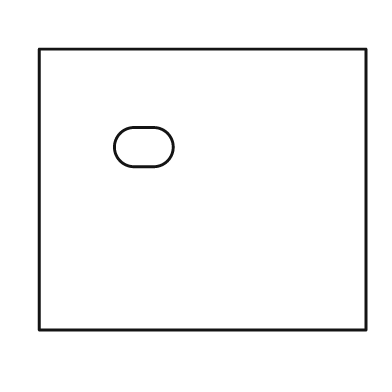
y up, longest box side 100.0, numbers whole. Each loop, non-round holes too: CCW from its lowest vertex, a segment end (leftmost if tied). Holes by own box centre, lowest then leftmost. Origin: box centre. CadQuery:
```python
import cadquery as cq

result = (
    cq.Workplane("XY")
    .moveTo(-50.0, -43.0)
    .lineTo(50.0, -43.0)
    .lineTo(50.0, 43.0)
    .lineTo(-50.0, 43.0)
    .close()
    .moveTo(-21.0, 7.0)
    .lineTo(-15.0, 7.0)
    .threePointArc((-9.0, 13.0), (-15.0, 19.0))
    .lineTo(-21.0, 19.0)
    .threePointArc((-27.0, 13.0), (-21.0, 7.0))
    .close()
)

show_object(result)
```